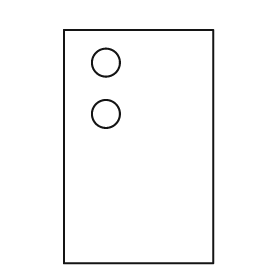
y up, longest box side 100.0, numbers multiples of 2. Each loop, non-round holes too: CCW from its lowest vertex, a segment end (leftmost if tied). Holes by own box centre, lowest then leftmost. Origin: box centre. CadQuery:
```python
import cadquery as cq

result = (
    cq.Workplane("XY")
    .moveTo(-32.0, -50.0)
    .lineTo(32.0, -50.0)
    .lineTo(32.0, 50.0)
    .lineTo(-32.0, 50.0)
    .close()
    .moveTo(-14.0, 14.0)
    .circle(6.0)
    .moveTo(-14.0, 36.0)
    .circle(6.0)
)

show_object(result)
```